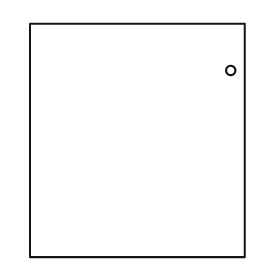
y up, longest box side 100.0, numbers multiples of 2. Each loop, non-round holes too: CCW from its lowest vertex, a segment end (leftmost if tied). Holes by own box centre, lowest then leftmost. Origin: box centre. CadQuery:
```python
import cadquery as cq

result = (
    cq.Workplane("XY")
    .moveTo(-46.0, -50.0)
    .lineTo(46.0, -50.0)
    .lineTo(46.0, 50.0)
    .lineTo(-46.0, 50.0)
    .close()
    .moveTo(40.0, 30.0)
    .circle(2.0)
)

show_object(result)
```